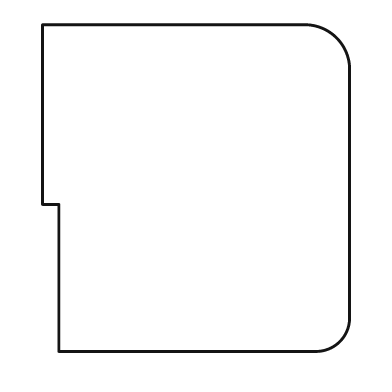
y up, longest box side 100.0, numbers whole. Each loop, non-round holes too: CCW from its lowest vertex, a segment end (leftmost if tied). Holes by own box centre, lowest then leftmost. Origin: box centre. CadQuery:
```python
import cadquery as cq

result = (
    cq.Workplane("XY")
    .moveTo(-42.0, -50.0)
    .lineTo(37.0, -50.0)
    .threePointArc((44.0, -47.0), (47.0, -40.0))
    .lineTo(47.0, 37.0)
    .threePointArc((43.0, 46.0), (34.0, 50.0))
    .lineTo(-47.0, 50.0)
    .lineTo(-47.0, -5.0)
    .lineTo(-42.0, -5.0)
    .close()
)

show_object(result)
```